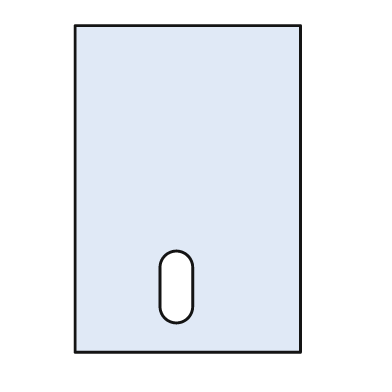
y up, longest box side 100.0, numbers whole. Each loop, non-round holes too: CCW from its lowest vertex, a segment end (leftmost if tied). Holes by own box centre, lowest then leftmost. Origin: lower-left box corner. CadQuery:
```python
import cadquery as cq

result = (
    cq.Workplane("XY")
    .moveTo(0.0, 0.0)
    .lineTo(69.0, 0.0)
    .lineTo(69.0, 100.0)
    .lineTo(0.0, 100.0)
    .close()
    .moveTo(26.0, 14.0)
    .threePointArc((31.0, 9.0), (36.0, 14.0))
    .lineTo(36.0, 26.0)
    .threePointArc((31.0, 31.0), (26.0, 26.0))
    .close()
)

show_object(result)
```